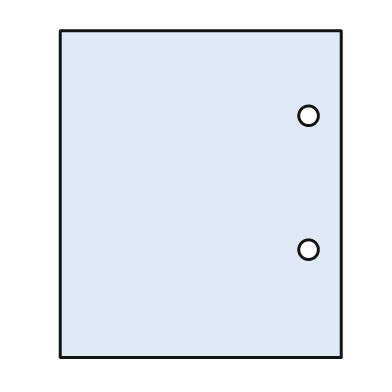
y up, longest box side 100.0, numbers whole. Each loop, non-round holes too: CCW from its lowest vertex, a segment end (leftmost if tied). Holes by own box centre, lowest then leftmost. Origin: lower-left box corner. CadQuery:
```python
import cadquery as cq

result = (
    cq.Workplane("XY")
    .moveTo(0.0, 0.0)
    .lineTo(86.0, 0.0)
    .lineTo(86.0, 100.0)
    .lineTo(0.0, 100.0)
    .close()
    .moveTo(76.0, 33.0)
    .circle(3.0)
    .moveTo(76.0, 74.0)
    .circle(3.0)
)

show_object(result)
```